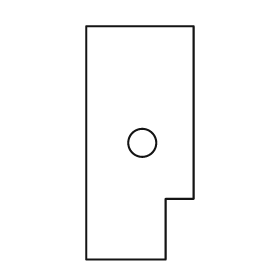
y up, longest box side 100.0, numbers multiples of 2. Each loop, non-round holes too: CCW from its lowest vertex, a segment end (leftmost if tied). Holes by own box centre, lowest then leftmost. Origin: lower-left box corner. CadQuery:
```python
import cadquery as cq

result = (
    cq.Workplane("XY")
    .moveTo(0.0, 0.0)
    .lineTo(34.0, 0.0)
    .lineTo(34.0, 26.0)
    .lineTo(46.0, 26.0)
    .lineTo(46.0, 100.0)
    .lineTo(0.0, 100.0)
    .close()
    .moveTo(24.0, 50.0)
    .circle(6.0)
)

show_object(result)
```